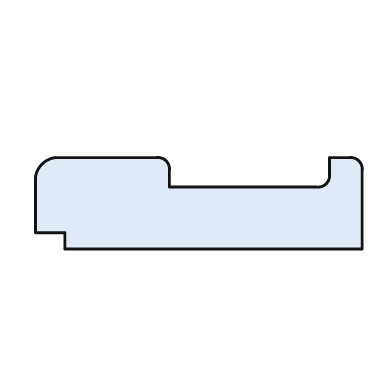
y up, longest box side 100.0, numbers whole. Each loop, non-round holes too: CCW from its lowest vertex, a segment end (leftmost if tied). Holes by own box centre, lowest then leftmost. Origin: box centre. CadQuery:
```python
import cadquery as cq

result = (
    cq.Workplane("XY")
    .moveTo(-41.0, -14.0)
    .lineTo(50.0, -14.0)
    .lineTo(50.0, 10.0)
    .threePointArc((49.0, 13.0), (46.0, 14.0))
    .lineTo(40.0, 14.0)
    .lineTo(40.0, 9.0)
    .threePointArc((39.0, 6.0), (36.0, 5.0))
    .lineTo(-9.0, 5.0)
    .lineTo(-9.0, 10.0)
    .threePointArc((-10.0, 13.0), (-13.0, 14.0))
    .lineTo(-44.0, 14.0)
    .threePointArc((-48.0, 12.0), (-50.0, 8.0))
    .lineTo(-50.0, -9.0)
    .lineTo(-41.0, -9.0)
    .close()
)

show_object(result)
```